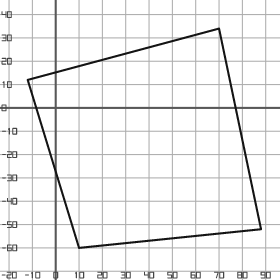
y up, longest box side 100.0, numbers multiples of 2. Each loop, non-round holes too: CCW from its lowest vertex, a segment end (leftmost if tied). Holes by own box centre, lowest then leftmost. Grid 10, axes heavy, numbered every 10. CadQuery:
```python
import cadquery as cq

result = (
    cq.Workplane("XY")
    .moveTo(10.0, -60.0)
    .lineTo(88.0, -52.0)
    .lineTo(70.0, 34.0)
    .lineTo(-12.0, 12.0)
    .close()
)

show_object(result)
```